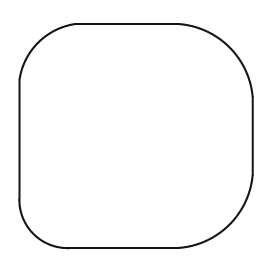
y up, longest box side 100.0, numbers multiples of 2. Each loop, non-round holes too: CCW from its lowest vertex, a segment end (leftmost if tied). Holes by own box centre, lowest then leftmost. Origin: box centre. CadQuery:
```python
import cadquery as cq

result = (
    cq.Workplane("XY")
    .moveTo(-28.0, -48.0)
    .lineTo(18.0, -48.0)
    .threePointArc((40.0, -38.0), (50.0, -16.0))
    .lineTo(50.0, 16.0)
    .threePointArc((40.0, 38.0), (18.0, 48.0))
    .lineTo(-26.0, 48.0)
    .threePointArc((-42.0, 40.0), (-50.0, 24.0))
    .lineTo(-50.0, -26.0)
    .threePointArc((-44.0, -42.0), (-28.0, -48.0))
    .close()
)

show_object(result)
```